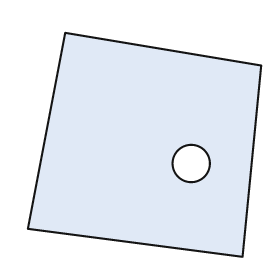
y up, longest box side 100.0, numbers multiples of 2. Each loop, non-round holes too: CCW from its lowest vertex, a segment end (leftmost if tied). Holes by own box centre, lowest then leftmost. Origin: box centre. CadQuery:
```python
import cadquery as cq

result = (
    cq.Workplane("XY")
    .moveTo(42.0, -48.0)
    .lineTo(50.0, 34.0)
    .lineTo(-34.0, 48.0)
    .lineTo(-50.0, -36.0)
    .close()
    .moveTo(20.0, -8.0)
    .circle(8.0)
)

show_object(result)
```